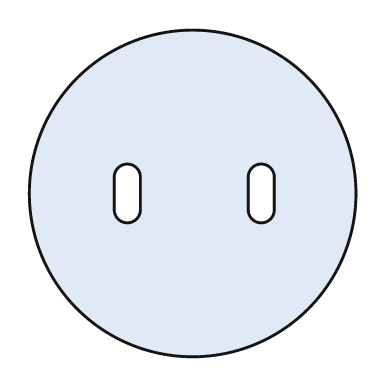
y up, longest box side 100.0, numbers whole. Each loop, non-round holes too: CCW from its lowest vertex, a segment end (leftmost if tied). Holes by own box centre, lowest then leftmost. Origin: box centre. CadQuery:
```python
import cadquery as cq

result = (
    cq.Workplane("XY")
    .moveTo(0.0, 0.0)
    .circle(50.0)
    .moveTo(-24.0, -5.0)
    .threePointArc((-20.0, -9.0), (-16.0, -5.0))
    .lineTo(-16.0, 5.0)
    .threePointArc((-20.0, 9.0), (-24.0, 5.0))
    .close()
    .moveTo(17.0, -5.0)
    .threePointArc((21.0, -9.0), (25.0, -5.0))
    .lineTo(25.0, 5.0)
    .threePointArc((21.0, 9.0), (17.0, 5.0))
    .close()
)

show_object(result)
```